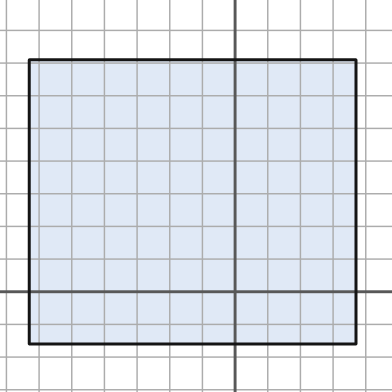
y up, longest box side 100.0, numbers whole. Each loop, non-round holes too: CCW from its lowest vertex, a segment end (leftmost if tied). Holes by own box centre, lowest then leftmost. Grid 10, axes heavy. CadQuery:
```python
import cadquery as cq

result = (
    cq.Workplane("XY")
    .moveTo(-63.0, -16.0)
    .lineTo(37.0, -16.0)
    .lineTo(37.0, 71.0)
    .lineTo(-63.0, 71.0)
    .close()
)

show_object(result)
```